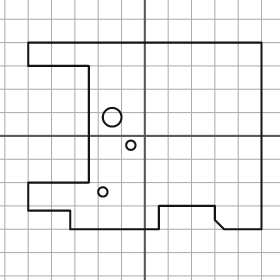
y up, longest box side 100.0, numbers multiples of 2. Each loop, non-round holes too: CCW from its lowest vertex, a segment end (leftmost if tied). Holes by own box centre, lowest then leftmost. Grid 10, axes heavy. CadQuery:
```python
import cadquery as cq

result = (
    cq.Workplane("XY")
    .moveTo(-32.0, -40.0)
    .lineTo(6.0, -40.0)
    .lineTo(6.0, -30.0)
    .lineTo(30.0, -30.0)
    .lineTo(30.0, -36.0)
    .lineTo(34.0, -40.0)
    .lineTo(50.0, -40.0)
    .lineTo(50.0, 40.0)
    .lineTo(-50.0, 40.0)
    .lineTo(-50.0, 30.0)
    .lineTo(-24.0, 30.0)
    .lineTo(-24.0, -20.0)
    .lineTo(-50.0, -20.0)
    .lineTo(-50.0, -32.0)
    .lineTo(-32.0, -32.0)
    .close()
    .moveTo(-18.0, -24.0)
    .circle(2.0)
    .moveTo(-6.0, -4.0)
    .circle(2.0)
    .moveTo(-14.0, 8.0)
    .circle(4.0)
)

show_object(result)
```